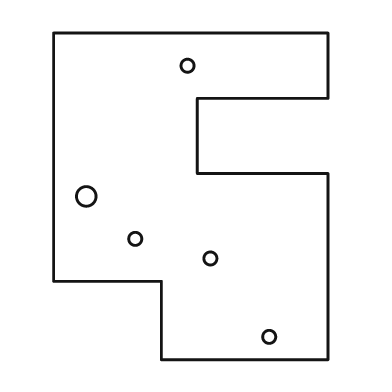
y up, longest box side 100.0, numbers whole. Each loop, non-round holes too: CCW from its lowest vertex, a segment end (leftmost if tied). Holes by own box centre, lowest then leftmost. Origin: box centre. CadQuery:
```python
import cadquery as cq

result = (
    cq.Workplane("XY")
    .moveTo(-9.0, -50.0)
    .lineTo(42.0, -50.0)
    .lineTo(42.0, 7.0)
    .lineTo(2.0, 7.0)
    .lineTo(2.0, 30.0)
    .lineTo(42.0, 30.0)
    .lineTo(42.0, 50.0)
    .lineTo(-42.0, 50.0)
    .lineTo(-42.0, -26.0)
    .lineTo(-9.0, -26.0)
    .close()
    .moveTo(24.0, -43.0)
    .circle(2.0)
    .moveTo(6.0, -19.0)
    .circle(2.0)
    .moveTo(-17.0, -13.0)
    .circle(2.0)
    .moveTo(-32.0, 0.0)
    .circle(3.0)
    .moveTo(-1.0, 40.0)
    .circle(2.0)
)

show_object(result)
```